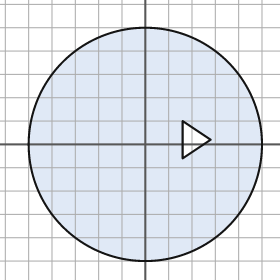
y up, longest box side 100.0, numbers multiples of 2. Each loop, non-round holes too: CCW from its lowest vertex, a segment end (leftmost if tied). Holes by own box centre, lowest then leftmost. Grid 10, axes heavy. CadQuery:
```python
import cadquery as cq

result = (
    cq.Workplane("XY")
    .moveTo(0.0, 0.0)
    .circle(50.0)
    .moveTo(16.0, -6.0)
    .lineTo(28.0, 2.0)
    .lineTo(16.0, 10.0)
    .close()
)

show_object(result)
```